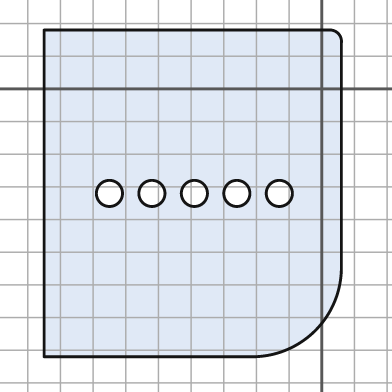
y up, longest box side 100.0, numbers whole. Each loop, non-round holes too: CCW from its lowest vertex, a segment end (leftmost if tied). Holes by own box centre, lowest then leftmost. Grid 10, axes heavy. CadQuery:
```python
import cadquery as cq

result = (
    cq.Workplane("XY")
    .moveTo(-85.0, -82.0)
    .lineTo(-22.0, -82.0)
    .threePointArc((-2.0, -74.0), (6.0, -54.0))
    .lineTo(6.0, 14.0)
    .threePointArc((5.0, 17.0), (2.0, 18.0))
    .lineTo(-85.0, 18.0)
    .close()
    .moveTo(-65.0, -32.0)
    .circle(4.0)
    .moveTo(-52.0, -32.0)
    .circle(4.0)
    .moveTo(-39.0, -32.0)
    .circle(4.0)
    .moveTo(-26.0, -32.0)
    .circle(4.0)
    .moveTo(-13.0, -32.0)
    .circle(4.0)
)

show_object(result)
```